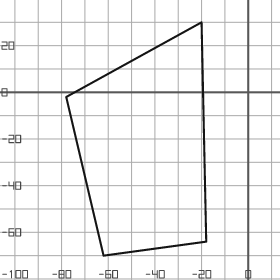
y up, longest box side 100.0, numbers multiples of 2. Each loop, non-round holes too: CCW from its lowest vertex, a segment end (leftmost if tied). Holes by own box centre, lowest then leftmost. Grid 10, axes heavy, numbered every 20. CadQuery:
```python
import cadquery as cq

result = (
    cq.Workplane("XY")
    .moveTo(-62.0, -70.0)
    .lineTo(-18.0, -64.0)
    .lineTo(-20.0, 30.0)
    .lineTo(-78.0, -2.0)
    .close()
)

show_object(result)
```